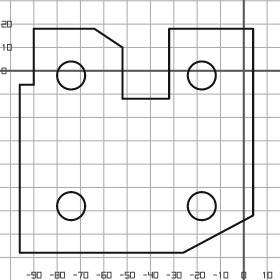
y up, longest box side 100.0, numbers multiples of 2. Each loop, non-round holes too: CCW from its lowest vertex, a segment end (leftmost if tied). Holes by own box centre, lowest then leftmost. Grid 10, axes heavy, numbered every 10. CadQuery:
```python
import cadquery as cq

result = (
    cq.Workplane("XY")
    .moveTo(-96.0, -78.0)
    .lineTo(-26.0, -78.0)
    .lineTo(4.0, -62.0)
    .lineTo(4.0, 18.0)
    .lineTo(-32.0, 18.0)
    .lineTo(-32.0, -12.0)
    .lineTo(-52.0, -12.0)
    .lineTo(-52.0, 10.0)
    .lineTo(-64.0, 18.0)
    .lineTo(-90.0, 18.0)
    .lineTo(-90.0, -6.0)
    .lineTo(-96.0, -6.0)
    .close()
    .moveTo(-74.0, -58.0)
    .circle(6.0)
    .moveTo(-18.0, -58.0)
    .circle(6.0)
    .moveTo(-74.0, -2.0)
    .circle(6.0)
    .moveTo(-18.0, -2.0)
    .circle(6.0)
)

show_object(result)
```